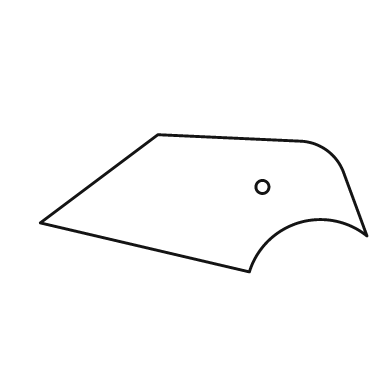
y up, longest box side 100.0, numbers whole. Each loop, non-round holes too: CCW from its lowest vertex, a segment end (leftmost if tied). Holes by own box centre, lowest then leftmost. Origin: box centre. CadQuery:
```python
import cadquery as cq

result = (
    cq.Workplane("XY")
    .moveTo(14.0, -21.0)
    .threePointArc((29.0, -6.0), (50.0, -10.0))
    .lineTo(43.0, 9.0)
    .threePointArc((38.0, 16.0), (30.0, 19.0))
    .lineTo(-14.0, 21.0)
    .lineTo(-50.0, -6.0)
    .close()
    .moveTo(18.0, 5.0)
    .circle(2.0)
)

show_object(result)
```